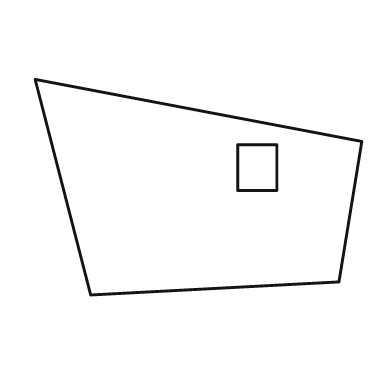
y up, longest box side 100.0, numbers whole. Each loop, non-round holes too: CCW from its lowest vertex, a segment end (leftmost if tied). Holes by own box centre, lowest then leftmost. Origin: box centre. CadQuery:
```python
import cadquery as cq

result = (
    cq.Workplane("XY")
    .moveTo(-33.0, -33.0)
    .lineTo(43.0, -29.0)
    .lineTo(50.0, 14.0)
    .lineTo(-50.0, 33.0)
    .close()
    .moveTo(12.0, -1.0)
    .lineTo(24.0, -1.0)
    .lineTo(24.0, 13.0)
    .lineTo(12.0, 13.0)
    .close()
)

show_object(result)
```